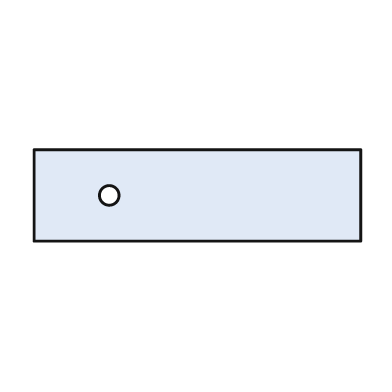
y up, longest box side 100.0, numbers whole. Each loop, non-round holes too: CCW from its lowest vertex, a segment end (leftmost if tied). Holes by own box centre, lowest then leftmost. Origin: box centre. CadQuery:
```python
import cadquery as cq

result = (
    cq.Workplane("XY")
    .moveTo(-50.0, -14.0)
    .lineTo(50.0, -14.0)
    .lineTo(50.0, 14.0)
    .lineTo(-50.0, 14.0)
    .close()
    .moveTo(-27.0, 0.0)
    .circle(3.0)
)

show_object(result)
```